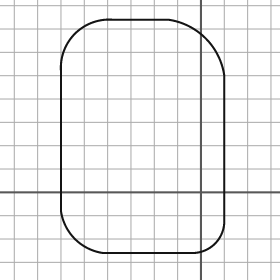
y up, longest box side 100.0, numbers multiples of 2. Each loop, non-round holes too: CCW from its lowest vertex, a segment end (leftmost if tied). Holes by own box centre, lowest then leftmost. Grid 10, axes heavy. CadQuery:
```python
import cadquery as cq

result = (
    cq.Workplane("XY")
    .moveTo(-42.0, -26.0)
    .lineTo(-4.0, -26.0)
    .threePointArc((6.0, -22.0), (10.0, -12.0))
    .lineTo(10.0, 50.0)
    .threePointArc((2.0, 66.0), (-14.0, 74.0))
    .lineTo(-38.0, 74.0)
    .threePointArc((-54.0, 68.0), (-60.0, 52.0))
    .lineTo(-60.0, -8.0)
    .threePointArc((-54.0, -20.0), (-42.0, -26.0))
    .close()
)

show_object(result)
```